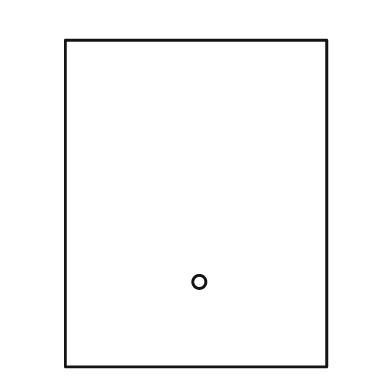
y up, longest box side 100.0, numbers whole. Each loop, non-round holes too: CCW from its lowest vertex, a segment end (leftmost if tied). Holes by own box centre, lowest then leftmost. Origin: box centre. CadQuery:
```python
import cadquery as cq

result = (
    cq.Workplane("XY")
    .moveTo(-40.0, -50.0)
    .lineTo(40.0, -50.0)
    .lineTo(40.0, 50.0)
    .lineTo(-40.0, 50.0)
    .close()
    .moveTo(1.0, -24.0)
    .circle(2.0)
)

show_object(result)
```